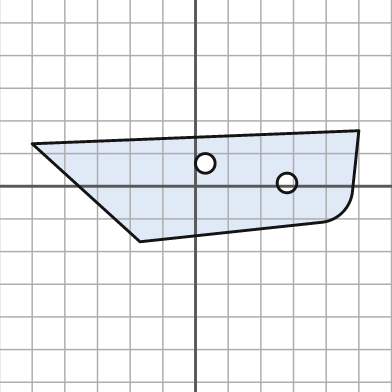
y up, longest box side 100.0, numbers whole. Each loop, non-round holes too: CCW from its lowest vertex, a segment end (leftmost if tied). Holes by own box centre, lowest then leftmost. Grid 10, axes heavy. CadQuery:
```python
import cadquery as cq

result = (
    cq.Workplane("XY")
    .moveTo(-17.0, -17.0)
    .lineTo(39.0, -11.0)
    .threePointArc((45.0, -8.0), (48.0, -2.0))
    .lineTo(50.0, 17.0)
    .lineTo(-50.0, 13.0)
    .close()
    .moveTo(28.0, 1.0)
    .circle(3.0)
    .moveTo(3.0, 7.0)
    .circle(3.0)
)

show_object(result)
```